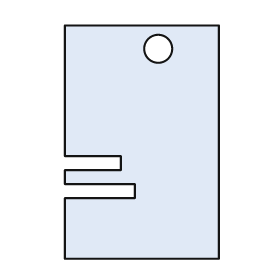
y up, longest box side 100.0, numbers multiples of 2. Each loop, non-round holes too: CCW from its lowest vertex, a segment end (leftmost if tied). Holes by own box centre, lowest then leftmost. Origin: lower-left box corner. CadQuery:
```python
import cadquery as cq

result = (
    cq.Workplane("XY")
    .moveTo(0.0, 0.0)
    .lineTo(66.0, 0.0)
    .lineTo(66.0, 100.0)
    .lineTo(0.0, 100.0)
    .lineTo(0.0, 44.0)
    .lineTo(24.0, 44.0)
    .lineTo(24.0, 38.0)
    .lineTo(0.0, 38.0)
    .lineTo(0.0, 32.0)
    .lineTo(30.0, 32.0)
    .lineTo(30.0, 26.0)
    .lineTo(0.0, 26.0)
    .close()
    .moveTo(40.0, 90.0)
    .circle(6.0)
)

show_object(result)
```